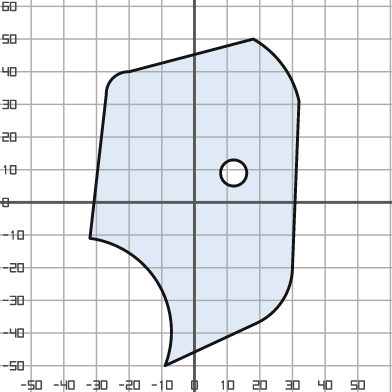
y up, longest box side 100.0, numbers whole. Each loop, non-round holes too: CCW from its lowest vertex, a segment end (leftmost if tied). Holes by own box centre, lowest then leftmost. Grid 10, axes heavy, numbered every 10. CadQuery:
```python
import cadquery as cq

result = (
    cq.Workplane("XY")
    .moveTo(-9.0, -50.0)
    .lineTo(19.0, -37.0)
    .threePointArc((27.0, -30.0), (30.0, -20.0))
    .lineTo(32.0, 31.0)
    .threePointArc((27.0, 42.0), (18.0, 50.0))
    .lineTo(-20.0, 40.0)
    .threePointArc((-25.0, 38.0), (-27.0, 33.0))
    .lineTo(-32.0, -11.0)
    .threePointArc((-11.0, -25.0), (-9.0, -50.0))
    .close()
    .moveTo(12.0, 9.0)
    .circle(4.0)
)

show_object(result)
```